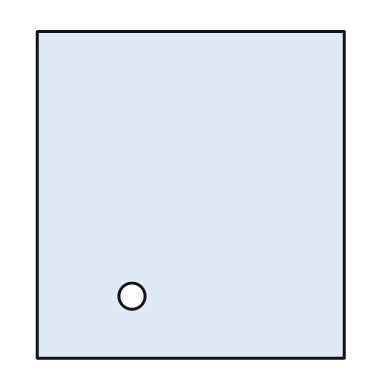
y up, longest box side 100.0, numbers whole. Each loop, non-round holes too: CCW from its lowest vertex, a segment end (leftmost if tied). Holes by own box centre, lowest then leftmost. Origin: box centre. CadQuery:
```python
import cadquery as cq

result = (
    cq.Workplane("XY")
    .moveTo(-47.0, -50.0)
    .lineTo(47.0, -50.0)
    .lineTo(47.0, 50.0)
    .lineTo(-47.0, 50.0)
    .close()
    .moveTo(-18.0, -31.0)
    .circle(4.0)
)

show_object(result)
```